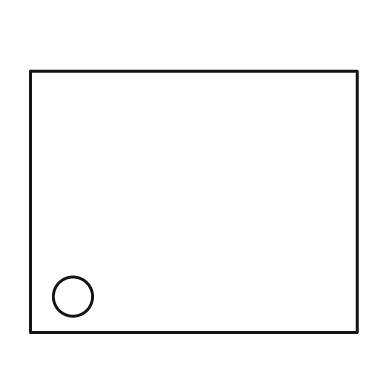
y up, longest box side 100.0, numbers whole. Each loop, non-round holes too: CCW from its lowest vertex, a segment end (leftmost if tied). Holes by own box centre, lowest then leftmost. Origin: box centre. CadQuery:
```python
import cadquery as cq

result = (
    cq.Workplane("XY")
    .moveTo(-50.0, -40.0)
    .lineTo(50.0, -40.0)
    .lineTo(50.0, 40.0)
    .lineTo(-50.0, 40.0)
    .close()
    .moveTo(-37.0, -29.0)
    .circle(6.0)
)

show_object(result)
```